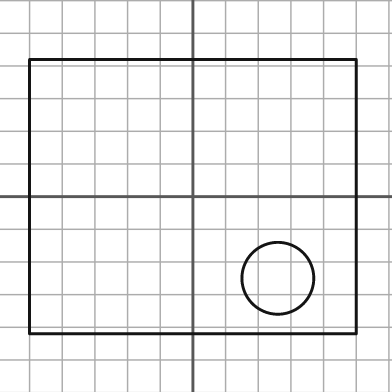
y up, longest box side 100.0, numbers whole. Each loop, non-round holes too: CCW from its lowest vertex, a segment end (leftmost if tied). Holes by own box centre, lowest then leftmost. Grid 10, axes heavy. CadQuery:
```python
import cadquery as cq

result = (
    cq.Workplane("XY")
    .moveTo(-50.0, -42.0)
    .lineTo(50.0, -42.0)
    .lineTo(50.0, 42.0)
    .lineTo(-50.0, 42.0)
    .close()
    .moveTo(26.0, -25.0)
    .circle(11.0)
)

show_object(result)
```